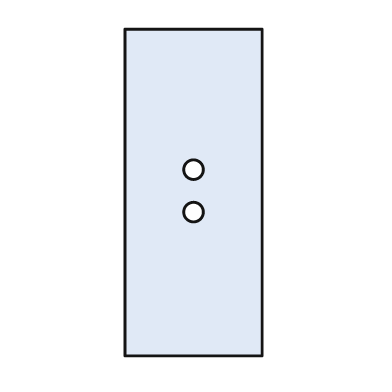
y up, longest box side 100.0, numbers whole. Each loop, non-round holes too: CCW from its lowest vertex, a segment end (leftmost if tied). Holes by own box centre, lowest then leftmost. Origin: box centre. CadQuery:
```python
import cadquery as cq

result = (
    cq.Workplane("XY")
    .moveTo(-21.0, -50.0)
    .lineTo(21.0, -50.0)
    .lineTo(21.0, 50.0)
    .lineTo(-21.0, 50.0)
    .close()
    .moveTo(0.0, -6.0)
    .circle(3.0)
    .moveTo(0.0, 7.0)
    .circle(3.0)
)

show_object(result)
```